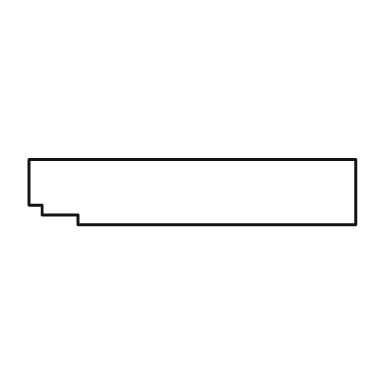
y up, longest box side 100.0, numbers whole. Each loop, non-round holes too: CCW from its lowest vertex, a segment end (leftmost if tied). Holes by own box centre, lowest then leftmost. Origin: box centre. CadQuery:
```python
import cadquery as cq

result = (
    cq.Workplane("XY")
    .moveTo(-35.0, -10.0)
    .lineTo(50.0, -10.0)
    .lineTo(50.0, 10.0)
    .lineTo(-50.0, 10.0)
    .lineTo(-50.0, -4.0)
    .lineTo(-46.0, -4.0)
    .lineTo(-46.0, -7.0)
    .lineTo(-35.0, -7.0)
    .close()
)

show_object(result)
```